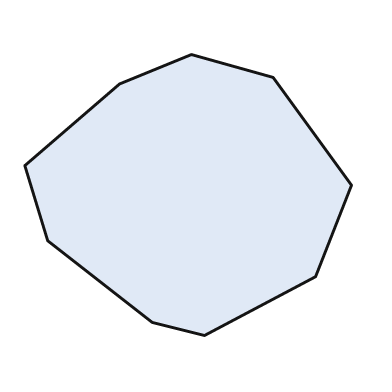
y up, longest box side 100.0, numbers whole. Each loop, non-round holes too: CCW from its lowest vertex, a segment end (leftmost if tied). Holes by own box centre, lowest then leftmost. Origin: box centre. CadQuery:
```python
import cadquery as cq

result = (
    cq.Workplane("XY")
    .moveTo(5.0, -43.0)
    .lineTo(39.0, -25.0)
    .lineTo(50.0, 3.0)
    .lineTo(26.0, 36.0)
    .lineTo(1.0, 43.0)
    .lineTo(-21.0, 34.0)
    .lineTo(-50.0, 9.0)
    .lineTo(-43.0, -14.0)
    .lineTo(-11.0, -39.0)
    .close()
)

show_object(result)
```